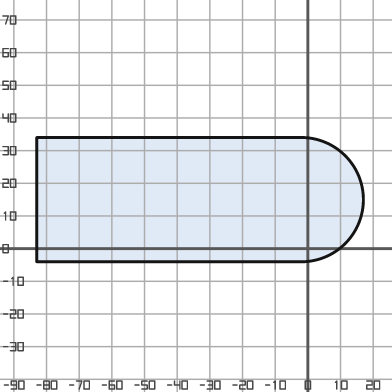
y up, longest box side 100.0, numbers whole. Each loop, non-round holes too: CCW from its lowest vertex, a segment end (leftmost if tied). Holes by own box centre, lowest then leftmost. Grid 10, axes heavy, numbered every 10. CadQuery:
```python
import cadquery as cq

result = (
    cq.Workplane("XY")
    .moveTo(-83.0, -4.0)
    .lineTo(-1.0, -4.0)
    .threePointArc((17.0, 15.0), (-1.0, 34.0))
    .lineTo(-83.0, 34.0)
    .close()
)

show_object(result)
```